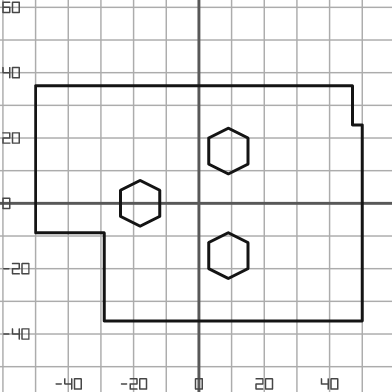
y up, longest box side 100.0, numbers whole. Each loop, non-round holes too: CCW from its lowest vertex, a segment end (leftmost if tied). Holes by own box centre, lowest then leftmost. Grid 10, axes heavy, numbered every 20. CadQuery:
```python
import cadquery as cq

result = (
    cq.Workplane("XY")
    .moveTo(-29.0, -36.0)
    .lineTo(50.0, -36.0)
    .lineTo(50.0, 24.0)
    .lineTo(47.0, 24.0)
    .lineTo(47.0, 36.0)
    .lineTo(-50.0, 36.0)
    .lineTo(-50.0, -9.0)
    .lineTo(-29.0, -9.0)
    .close()
    .moveTo(9.0, -23.0)
    .lineTo(15.0, -20.0)
    .lineTo(15.0, -12.0)
    .lineTo(9.0, -9.0)
    .lineTo(3.0, -12.0)
    .lineTo(3.0, -20.0)
    .close()
    .moveTo(-18.0, -7.0)
    .lineTo(-12.0, -4.0)
    .lineTo(-12.0, 4.0)
    .lineTo(-18.0, 7.0)
    .lineTo(-24.0, 4.0)
    .lineTo(-24.0, -4.0)
    .close()
    .moveTo(9.0, 9.0)
    .lineTo(15.0, 12.0)
    .lineTo(15.0, 20.0)
    .lineTo(9.0, 23.0)
    .lineTo(3.0, 20.0)
    .lineTo(3.0, 12.0)
    .close()
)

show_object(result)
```